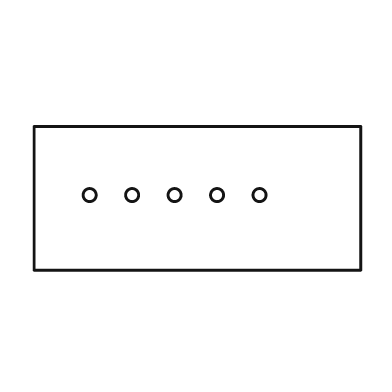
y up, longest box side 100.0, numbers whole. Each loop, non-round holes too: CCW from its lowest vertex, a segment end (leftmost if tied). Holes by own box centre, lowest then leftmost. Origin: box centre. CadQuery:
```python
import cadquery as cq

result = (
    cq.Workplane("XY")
    .moveTo(-50.0, -22.0)
    .lineTo(50.0, -22.0)
    .lineTo(50.0, 22.0)
    .lineTo(-50.0, 22.0)
    .close()
    .moveTo(-33.0, 1.0)
    .circle(2.0)
    .moveTo(-20.0, 1.0)
    .circle(2.0)
    .moveTo(-7.0, 1.0)
    .circle(2.0)
    .moveTo(6.0, 1.0)
    .circle(2.0)
    .moveTo(19.0, 1.0)
    .circle(2.0)
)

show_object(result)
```